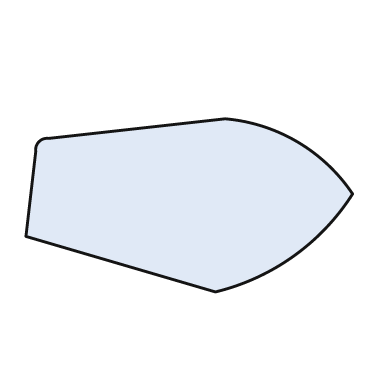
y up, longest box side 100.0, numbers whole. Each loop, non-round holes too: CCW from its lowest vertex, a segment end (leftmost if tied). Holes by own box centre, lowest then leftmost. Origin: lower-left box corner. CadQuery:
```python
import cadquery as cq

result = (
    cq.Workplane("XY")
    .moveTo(58.0, 0.0)
    .threePointArc((82.0, 11.0), (100.0, 30.0))
    .threePointArc((83.0, 46.0), (61.0, 53.0))
    .lineTo(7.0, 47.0)
    .threePointArc((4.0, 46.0), (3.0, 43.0))
    .lineTo(0.0, 17.0)
    .close()
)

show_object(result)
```